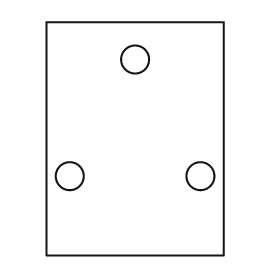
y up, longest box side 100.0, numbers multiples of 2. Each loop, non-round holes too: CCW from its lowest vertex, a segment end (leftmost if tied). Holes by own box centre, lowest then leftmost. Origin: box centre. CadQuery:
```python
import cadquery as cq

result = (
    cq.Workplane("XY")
    .moveTo(-38.0, -50.0)
    .lineTo(38.0, -50.0)
    .lineTo(38.0, 50.0)
    .lineTo(-38.0, 50.0)
    .close()
    .moveTo(-28.0, -16.0)
    .circle(6.0)
    .moveTo(28.0, -16.0)
    .circle(6.0)
    .moveTo(0.0, 34.0)
    .circle(6.0)
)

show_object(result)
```